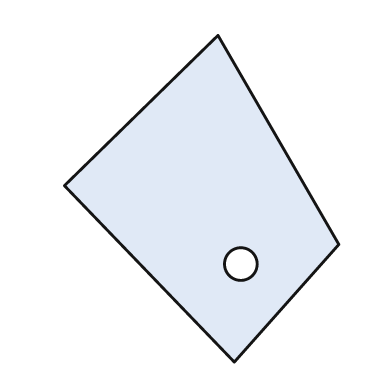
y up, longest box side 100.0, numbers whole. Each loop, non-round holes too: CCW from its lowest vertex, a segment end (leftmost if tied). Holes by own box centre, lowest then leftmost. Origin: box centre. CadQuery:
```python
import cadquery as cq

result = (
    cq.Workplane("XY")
    .moveTo(10.0, -50.0)
    .lineTo(42.0, -14.0)
    .lineTo(5.0, 50.0)
    .lineTo(-42.0, 4.0)
    .close()
    .moveTo(12.0, -20.0)
    .circle(5.0)
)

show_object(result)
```